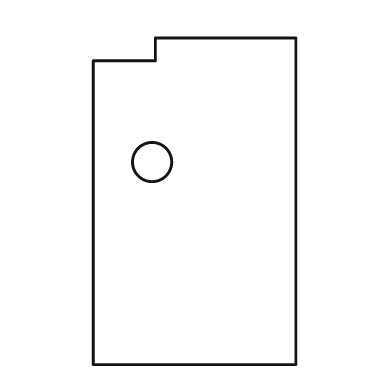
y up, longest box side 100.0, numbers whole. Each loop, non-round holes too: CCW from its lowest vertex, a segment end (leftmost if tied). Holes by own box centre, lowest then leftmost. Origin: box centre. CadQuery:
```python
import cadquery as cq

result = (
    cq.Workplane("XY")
    .moveTo(-31.0, -50.0)
    .lineTo(31.0, -50.0)
    .lineTo(31.0, 50.0)
    .lineTo(-12.0, 50.0)
    .lineTo(-12.0, 43.0)
    .lineTo(-31.0, 43.0)
    .close()
    .moveTo(-13.0, 12.0)
    .circle(6.0)
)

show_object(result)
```